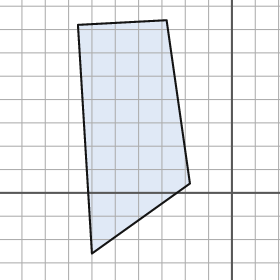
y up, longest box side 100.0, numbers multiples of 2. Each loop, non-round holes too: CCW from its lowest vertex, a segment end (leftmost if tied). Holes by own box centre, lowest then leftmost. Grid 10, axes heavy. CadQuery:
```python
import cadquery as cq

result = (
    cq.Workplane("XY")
    .moveTo(-60.0, -26.0)
    .lineTo(-18.0, 4.0)
    .lineTo(-28.0, 74.0)
    .lineTo(-66.0, 72.0)
    .close()
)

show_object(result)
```